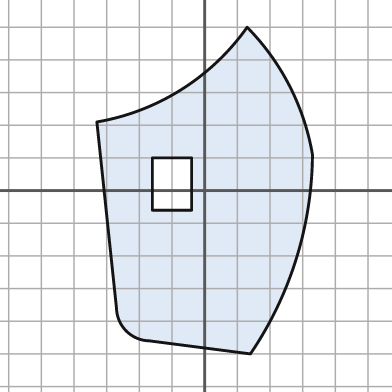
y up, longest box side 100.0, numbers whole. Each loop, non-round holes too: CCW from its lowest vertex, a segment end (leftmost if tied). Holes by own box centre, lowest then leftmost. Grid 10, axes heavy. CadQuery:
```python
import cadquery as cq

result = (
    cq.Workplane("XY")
    .moveTo(14.0, -50.0)
    .threePointArc((28.0, -21.0), (33.0, 11.0))
    .threePointArc((26.0, 32.0), (13.0, 50.0))
    .threePointArc((-7.0, 31.0), (-33.0, 21.0))
    .lineTo(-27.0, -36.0)
    .threePointArc((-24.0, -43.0), (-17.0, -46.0))
    .close()
    .moveTo(-16.0, -6.0)
    .lineTo(-4.0, -6.0)
    .lineTo(-4.0, 10.0)
    .lineTo(-16.0, 10.0)
    .close()
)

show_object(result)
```